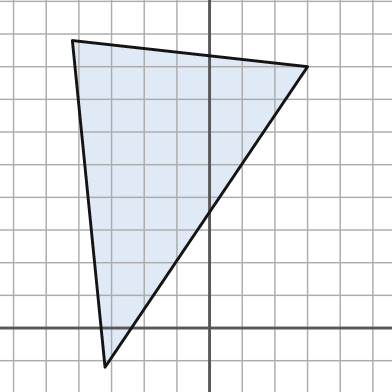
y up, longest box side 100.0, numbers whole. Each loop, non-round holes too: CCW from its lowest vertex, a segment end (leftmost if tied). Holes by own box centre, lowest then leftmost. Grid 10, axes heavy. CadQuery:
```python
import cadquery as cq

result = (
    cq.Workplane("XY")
    .moveTo(-32.0, -12.0)
    .lineTo(30.0, 80.0)
    .lineTo(-42.0, 88.0)
    .close()
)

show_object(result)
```